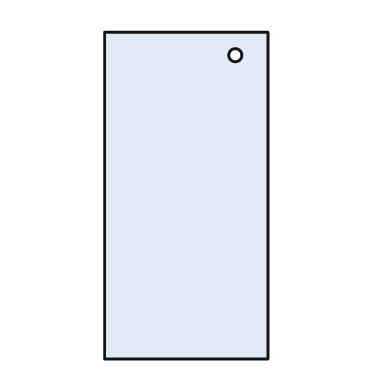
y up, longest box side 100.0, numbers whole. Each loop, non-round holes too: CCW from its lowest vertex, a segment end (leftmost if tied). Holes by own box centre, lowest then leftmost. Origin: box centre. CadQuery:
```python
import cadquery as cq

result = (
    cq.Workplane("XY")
    .moveTo(-25.0, -50.0)
    .lineTo(25.0, -50.0)
    .lineTo(25.0, 50.0)
    .lineTo(-25.0, 50.0)
    .close()
    .moveTo(15.0, 43.0)
    .circle(2.0)
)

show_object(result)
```